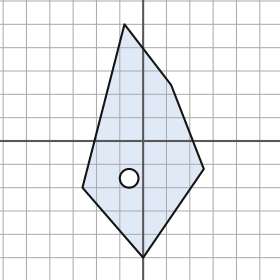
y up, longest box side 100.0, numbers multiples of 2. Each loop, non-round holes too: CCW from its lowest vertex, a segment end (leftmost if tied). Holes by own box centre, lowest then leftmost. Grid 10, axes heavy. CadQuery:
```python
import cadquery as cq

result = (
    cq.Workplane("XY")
    .moveTo(0.0, -50.0)
    .lineTo(26.0, -12.0)
    .lineTo(12.0, 24.0)
    .lineTo(-8.0, 50.0)
    .lineTo(-26.0, -20.0)
    .close()
    .moveTo(-6.0, -16.0)
    .circle(4.0)
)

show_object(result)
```